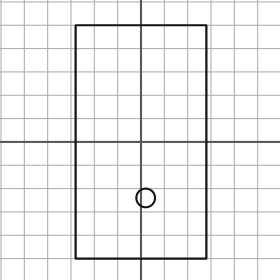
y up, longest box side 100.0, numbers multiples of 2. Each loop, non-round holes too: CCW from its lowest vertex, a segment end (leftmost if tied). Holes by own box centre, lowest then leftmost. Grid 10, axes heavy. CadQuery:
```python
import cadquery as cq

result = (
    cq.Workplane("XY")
    .moveTo(-28.0, -50.0)
    .lineTo(28.0, -50.0)
    .lineTo(28.0, 50.0)
    .lineTo(-28.0, 50.0)
    .close()
    .moveTo(2.0, -24.0)
    .circle(4.0)
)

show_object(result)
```